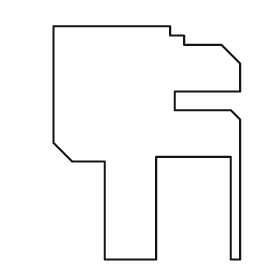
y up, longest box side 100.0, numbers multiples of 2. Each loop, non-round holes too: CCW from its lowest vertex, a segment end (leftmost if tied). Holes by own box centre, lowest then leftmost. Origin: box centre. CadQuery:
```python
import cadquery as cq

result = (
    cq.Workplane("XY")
    .moveTo(-18.0, -50.0)
    .lineTo(4.0, -50.0)
    .lineTo(4.0, -6.0)
    .lineTo(36.0, -6.0)
    .lineTo(36.0, -50.0)
    .lineTo(40.0, -50.0)
    .lineTo(40.0, 10.0)
    .lineTo(36.0, 14.0)
    .lineTo(12.0, 14.0)
    .lineTo(12.0, 22.0)
    .lineTo(40.0, 22.0)
    .lineTo(40.0, 34.0)
    .lineTo(32.0, 42.0)
    .lineTo(16.0, 42.0)
    .lineTo(16.0, 46.0)
    .lineTo(10.0, 46.0)
    .lineTo(10.0, 50.0)
    .lineTo(-40.0, 50.0)
    .lineTo(-40.0, 0.0)
    .lineTo(-32.0, -8.0)
    .lineTo(-18.0, -8.0)
    .close()
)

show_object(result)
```